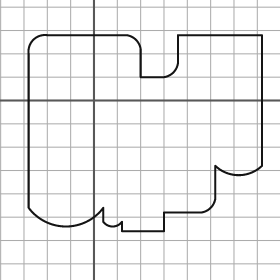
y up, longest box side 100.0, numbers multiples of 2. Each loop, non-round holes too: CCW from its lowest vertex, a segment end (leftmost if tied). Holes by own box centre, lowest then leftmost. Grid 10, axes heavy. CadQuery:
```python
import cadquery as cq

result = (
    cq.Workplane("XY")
    .moveTo(12.0, -56.0)
    .lineTo(30.0, -56.0)
    .lineTo(30.0, -48.0)
    .lineTo(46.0, -48.0)
    .threePointArc((50.0, -46.0), (52.0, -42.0))
    .lineTo(52.0, -28.0)
    .threePointArc((62.0, -32.0), (72.0, -28.0))
    .lineTo(72.0, 28.0)
    .lineTo(36.0, 28.0)
    .lineTo(36.0, 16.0)
    .threePointArc((34.0, 12.0), (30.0, 10.0))
    .lineTo(20.0, 10.0)
    .lineTo(20.0, 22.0)
    .threePointArc((18.0, 26.0), (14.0, 28.0))
    .lineTo(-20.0, 28.0)
    .threePointArc((-26.0, 26.0), (-28.0, 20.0))
    .lineTo(-28.0, -46.0)
    .threePointArc((-12.0, -54.0), (4.0, -46.0))
    .lineTo(4.0, -52.0)
    .threePointArc((8.0, -54.0), (12.0, -52.0))
    .close()
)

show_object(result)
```